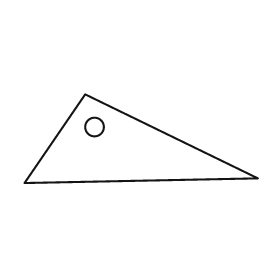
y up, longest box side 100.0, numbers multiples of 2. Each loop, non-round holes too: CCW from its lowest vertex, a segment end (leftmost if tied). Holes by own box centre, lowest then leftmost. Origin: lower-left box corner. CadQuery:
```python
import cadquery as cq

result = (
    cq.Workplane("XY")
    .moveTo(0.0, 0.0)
    .lineTo(100.0, 2.0)
    .lineTo(26.0, 38.0)
    .close()
    .moveTo(30.0, 24.0)
    .circle(4.0)
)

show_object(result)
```